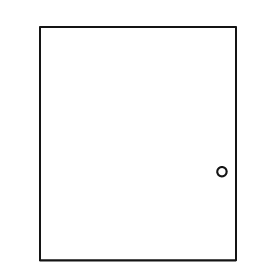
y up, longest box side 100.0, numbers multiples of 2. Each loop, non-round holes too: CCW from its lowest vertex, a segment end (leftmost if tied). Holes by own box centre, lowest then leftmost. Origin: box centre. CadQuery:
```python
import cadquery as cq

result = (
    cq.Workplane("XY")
    .moveTo(-42.0, -50.0)
    .lineTo(42.0, -50.0)
    .lineTo(42.0, 50.0)
    .lineTo(-42.0, 50.0)
    .close()
    .moveTo(36.0, -12.0)
    .circle(2.0)
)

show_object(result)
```